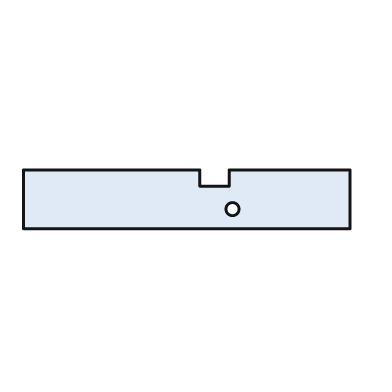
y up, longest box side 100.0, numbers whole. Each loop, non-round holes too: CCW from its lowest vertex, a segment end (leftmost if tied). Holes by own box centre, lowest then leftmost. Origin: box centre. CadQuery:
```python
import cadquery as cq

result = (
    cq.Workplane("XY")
    .moveTo(-50.0, -9.0)
    .lineTo(50.0, -9.0)
    .lineTo(50.0, 9.0)
    .lineTo(13.0, 9.0)
    .lineTo(13.0, 4.0)
    .lineTo(4.0, 4.0)
    .lineTo(4.0, 9.0)
    .lineTo(-50.0, 9.0)
    .close()
    .moveTo(14.0, -3.0)
    .circle(2.0)
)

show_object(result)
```